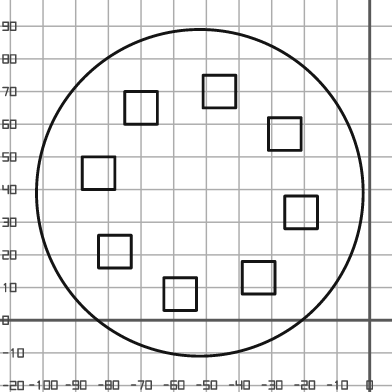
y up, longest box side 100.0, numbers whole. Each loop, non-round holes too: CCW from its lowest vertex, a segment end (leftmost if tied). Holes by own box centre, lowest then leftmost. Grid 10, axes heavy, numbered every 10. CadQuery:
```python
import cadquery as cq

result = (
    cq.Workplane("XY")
    .moveTo(-52.0, 39.0)
    .circle(50.0)
    .moveTo(-63.0, 3.0)
    .lineTo(-53.0, 3.0)
    .lineTo(-53.0, 13.0)
    .lineTo(-63.0, 13.0)
    .close()
    .moveTo(-39.0, 8.0)
    .lineTo(-29.0, 8.0)
    .lineTo(-29.0, 18.0)
    .lineTo(-39.0, 18.0)
    .close()
    .moveTo(-83.0, 16.0)
    .lineTo(-73.0, 16.0)
    .lineTo(-73.0, 26.0)
    .lineTo(-83.0, 26.0)
    .close()
    .moveTo(-26.0, 28.0)
    .lineTo(-16.0, 28.0)
    .lineTo(-16.0, 38.0)
    .lineTo(-26.0, 38.0)
    .close()
    .moveTo(-88.0, 40.0)
    .lineTo(-78.0, 40.0)
    .lineTo(-78.0, 50.0)
    .lineTo(-88.0, 50.0)
    .close()
    .moveTo(-31.0, 52.0)
    .lineTo(-21.0, 52.0)
    .lineTo(-21.0, 62.0)
    .lineTo(-31.0, 62.0)
    .close()
    .moveTo(-75.0, 60.0)
    .lineTo(-65.0, 60.0)
    .lineTo(-65.0, 70.0)
    .lineTo(-75.0, 70.0)
    .close()
    .moveTo(-51.0, 65.0)
    .lineTo(-41.0, 65.0)
    .lineTo(-41.0, 75.0)
    .lineTo(-51.0, 75.0)
    .close()
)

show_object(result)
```